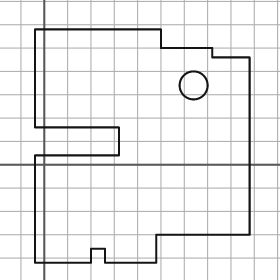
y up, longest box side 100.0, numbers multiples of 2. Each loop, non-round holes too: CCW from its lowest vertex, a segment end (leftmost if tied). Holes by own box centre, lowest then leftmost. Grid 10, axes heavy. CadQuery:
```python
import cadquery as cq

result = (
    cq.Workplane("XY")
    .moveTo(-4.0, -42.0)
    .lineTo(20.0, -42.0)
    .lineTo(20.0, -36.0)
    .lineTo(26.0, -36.0)
    .lineTo(26.0, -42.0)
    .lineTo(48.0, -42.0)
    .lineTo(48.0, -30.0)
    .lineTo(88.0, -30.0)
    .lineTo(88.0, 46.0)
    .lineTo(72.0, 46.0)
    .lineTo(72.0, 50.0)
    .lineTo(50.0, 50.0)
    .lineTo(50.0, 58.0)
    .lineTo(-4.0, 58.0)
    .lineTo(-4.0, 16.0)
    .lineTo(32.0, 16.0)
    .lineTo(32.0, 4.0)
    .lineTo(-4.0, 4.0)
    .close()
    .moveTo(64.0, 34.0)
    .circle(6.0)
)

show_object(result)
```